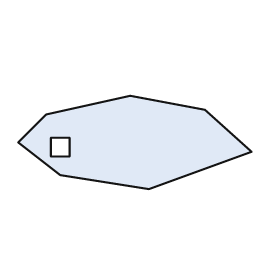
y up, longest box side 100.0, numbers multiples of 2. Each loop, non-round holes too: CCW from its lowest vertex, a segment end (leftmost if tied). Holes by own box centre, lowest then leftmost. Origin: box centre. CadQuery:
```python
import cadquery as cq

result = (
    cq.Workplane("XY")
    .moveTo(6.0, -20.0)
    .lineTo(50.0, -4.0)
    .lineTo(30.0, 14.0)
    .lineTo(-2.0, 20.0)
    .lineTo(-38.0, 12.0)
    .lineTo(-50.0, 0.0)
    .lineTo(-32.0, -14.0)
    .close()
    .moveTo(-36.0, -6.0)
    .lineTo(-28.0, -6.0)
    .lineTo(-28.0, 2.0)
    .lineTo(-36.0, 2.0)
    .close()
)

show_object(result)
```